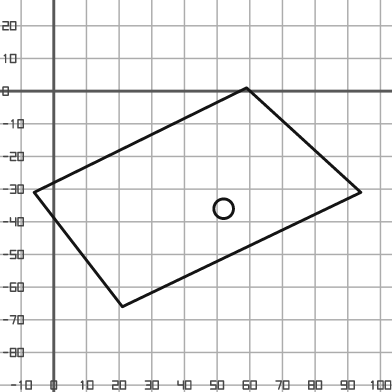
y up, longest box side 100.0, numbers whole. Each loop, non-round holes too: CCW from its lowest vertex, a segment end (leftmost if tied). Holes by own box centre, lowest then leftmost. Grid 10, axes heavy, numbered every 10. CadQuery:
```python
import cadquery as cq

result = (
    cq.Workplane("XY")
    .moveTo(21.0, -66.0)
    .lineTo(94.0, -31.0)
    .lineTo(59.0, 1.0)
    .lineTo(-6.0, -31.0)
    .close()
    .moveTo(52.0, -36.0)
    .circle(3.0)
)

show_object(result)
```